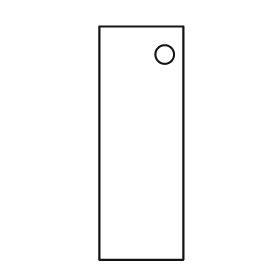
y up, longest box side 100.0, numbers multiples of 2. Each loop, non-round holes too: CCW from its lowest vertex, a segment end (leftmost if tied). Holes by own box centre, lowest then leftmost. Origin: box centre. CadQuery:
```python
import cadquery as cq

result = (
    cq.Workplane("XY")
    .moveTo(-18.0, -50.0)
    .lineTo(18.0, -50.0)
    .lineTo(18.0, 50.0)
    .lineTo(-18.0, 50.0)
    .close()
    .moveTo(10.0, 38.0)
    .circle(4.0)
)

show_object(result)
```